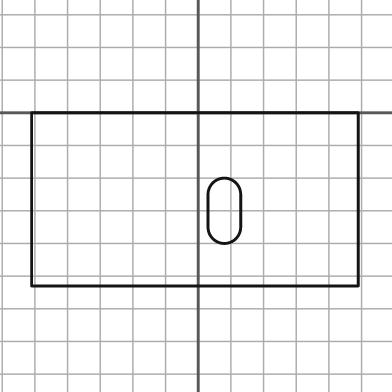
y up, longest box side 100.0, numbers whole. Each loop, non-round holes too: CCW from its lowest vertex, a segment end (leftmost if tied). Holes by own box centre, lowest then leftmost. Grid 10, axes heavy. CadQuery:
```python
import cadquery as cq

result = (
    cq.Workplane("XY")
    .moveTo(-51.0, -53.0)
    .lineTo(49.0, -53.0)
    .lineTo(49.0, 0.0)
    .lineTo(-51.0, 0.0)
    .close()
    .moveTo(3.0, -35.0)
    .threePointArc((8.0, -40.0), (13.0, -35.0))
    .lineTo(13.0, -25.0)
    .threePointArc((8.0, -20.0), (3.0, -25.0))
    .close()
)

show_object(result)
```